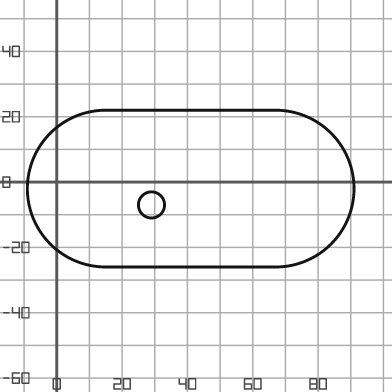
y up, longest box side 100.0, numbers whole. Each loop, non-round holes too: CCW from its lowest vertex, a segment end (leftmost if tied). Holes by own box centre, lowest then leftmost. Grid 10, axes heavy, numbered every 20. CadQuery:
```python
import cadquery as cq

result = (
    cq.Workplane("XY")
    .moveTo(15.0, -26.0)
    .lineTo(67.0, -26.0)
    .threePointArc((91.0, -2.0), (67.0, 22.0))
    .lineTo(15.0, 22.0)
    .threePointArc((-9.0, -2.0), (15.0, -26.0))
    .close()
    .moveTo(29.0, -7.0)
    .circle(4.0)
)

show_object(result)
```